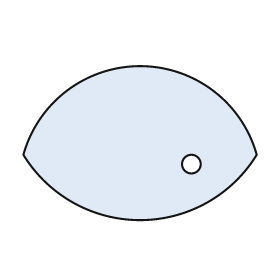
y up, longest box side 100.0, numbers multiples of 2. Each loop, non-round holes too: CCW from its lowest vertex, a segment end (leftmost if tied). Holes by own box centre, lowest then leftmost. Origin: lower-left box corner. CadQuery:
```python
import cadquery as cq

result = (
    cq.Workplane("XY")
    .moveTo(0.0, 28.0)
    .threePointArc((50.0, 0.0), (100.0, 28.0))
    .threePointArc((50.0, 66.0), (0.0, 28.0))
    .close()
    .moveTo(72.0, 24.0)
    .circle(4.0)
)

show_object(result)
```